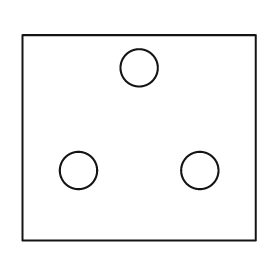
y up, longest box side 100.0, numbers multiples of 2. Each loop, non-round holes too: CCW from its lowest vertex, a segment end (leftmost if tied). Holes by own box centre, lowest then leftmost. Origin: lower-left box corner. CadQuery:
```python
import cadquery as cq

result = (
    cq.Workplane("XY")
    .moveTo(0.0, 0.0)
    .lineTo(100.0, 0.0)
    .lineTo(100.0, 88.0)
    .lineTo(0.0, 88.0)
    .close()
    .moveTo(24.0, 30.0)
    .circle(8.0)
    .moveTo(76.0, 30.0)
    .circle(8.0)
    .moveTo(50.0, 74.0)
    .circle(8.0)
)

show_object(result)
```